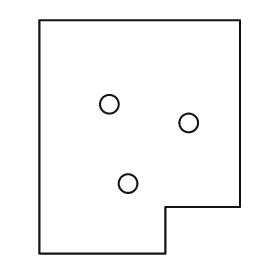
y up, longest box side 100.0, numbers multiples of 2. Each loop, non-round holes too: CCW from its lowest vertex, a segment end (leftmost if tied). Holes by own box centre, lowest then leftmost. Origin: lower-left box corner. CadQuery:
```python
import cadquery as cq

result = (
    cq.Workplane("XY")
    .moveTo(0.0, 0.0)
    .lineTo(54.0, 0.0)
    .lineTo(54.0, 20.0)
    .lineTo(86.0, 20.0)
    .lineTo(86.0, 100.0)
    .lineTo(0.0, 100.0)
    .close()
    .moveTo(38.0, 30.0)
    .circle(4.0)
    .moveTo(64.0, 56.0)
    .circle(4.0)
    .moveTo(30.0, 64.0)
    .circle(4.0)
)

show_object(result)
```